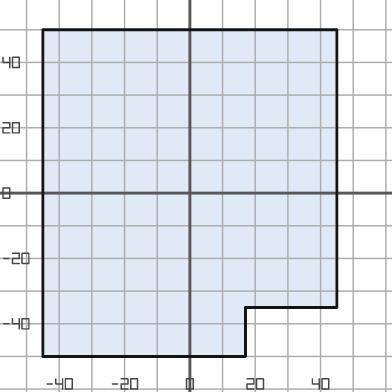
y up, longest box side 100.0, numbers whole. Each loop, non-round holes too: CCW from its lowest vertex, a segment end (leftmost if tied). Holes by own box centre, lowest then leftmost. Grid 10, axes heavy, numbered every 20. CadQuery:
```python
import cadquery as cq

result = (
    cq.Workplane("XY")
    .moveTo(-45.0, -50.0)
    .lineTo(17.0, -50.0)
    .lineTo(17.0, -35.0)
    .lineTo(45.0, -35.0)
    .lineTo(45.0, 50.0)
    .lineTo(-45.0, 50.0)
    .close()
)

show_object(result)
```